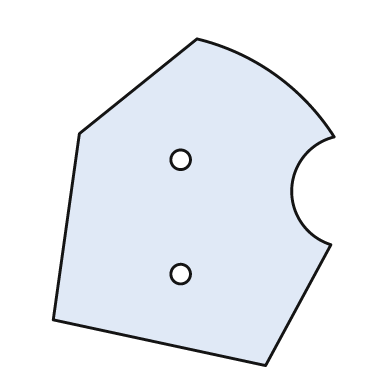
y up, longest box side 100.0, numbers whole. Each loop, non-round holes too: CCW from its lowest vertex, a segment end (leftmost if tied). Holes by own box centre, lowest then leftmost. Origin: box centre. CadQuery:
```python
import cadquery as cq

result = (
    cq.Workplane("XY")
    .moveTo(22.0, -50.0)
    .lineTo(42.0, -13.0)
    .threePointArc((30.0, 4.0), (43.0, 20.0))
    .threePointArc((25.0, 39.0), (1.0, 50.0))
    .lineTo(-35.0, 21.0)
    .lineTo(-43.0, -36.0)
    .close()
    .moveTo(-4.0, -22.0)
    .circle(3.0)
    .moveTo(-4.0, 13.0)
    .circle(3.0)
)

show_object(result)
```